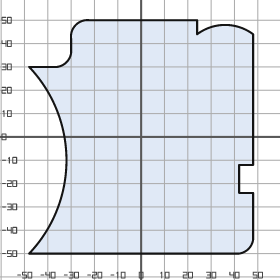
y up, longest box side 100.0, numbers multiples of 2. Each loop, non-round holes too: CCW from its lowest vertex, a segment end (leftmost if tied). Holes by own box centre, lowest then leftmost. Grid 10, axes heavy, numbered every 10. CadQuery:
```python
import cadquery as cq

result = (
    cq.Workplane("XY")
    .moveTo(-48.0, -50.0)
    .lineTo(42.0, -50.0)
    .threePointArc((46.0, -48.0), (48.0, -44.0))
    .lineTo(48.0, -24.0)
    .lineTo(42.0, -24.0)
    .lineTo(42.0, -12.0)
    .lineTo(48.0, -12.0)
    .lineTo(48.0, 44.0)
    .threePointArc((36.0, 48.0), (24.0, 44.0))
    .lineTo(24.0, 50.0)
    .lineTo(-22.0, 50.0)
    .threePointArc((-28.0, 48.0), (-30.0, 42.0))
    .lineTo(-30.0, 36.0)
    .threePointArc((-32.0, 32.0), (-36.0, 30.0))
    .lineTo(-48.0, 30.0)
    .threePointArc((-32.0, -10.0), (-48.0, -50.0))
    .close()
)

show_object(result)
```